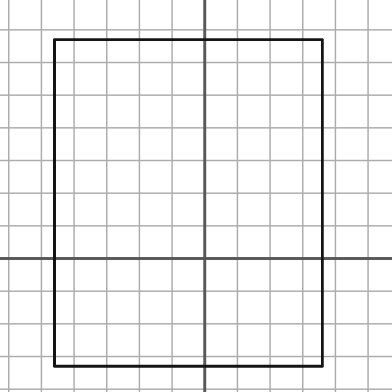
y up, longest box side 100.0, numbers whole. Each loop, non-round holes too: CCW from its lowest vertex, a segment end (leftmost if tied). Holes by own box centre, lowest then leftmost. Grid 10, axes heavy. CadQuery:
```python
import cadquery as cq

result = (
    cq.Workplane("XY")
    .moveTo(-46.0, -33.0)
    .lineTo(36.0, -33.0)
    .lineTo(36.0, 67.0)
    .lineTo(-46.0, 67.0)
    .close()
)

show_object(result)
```